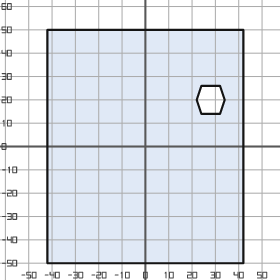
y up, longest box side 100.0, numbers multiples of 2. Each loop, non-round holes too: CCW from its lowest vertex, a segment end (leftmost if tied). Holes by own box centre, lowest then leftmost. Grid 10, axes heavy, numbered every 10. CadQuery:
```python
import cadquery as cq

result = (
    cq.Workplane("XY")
    .moveTo(-42.0, -50.0)
    .lineTo(42.0, -50.0)
    .lineTo(42.0, 50.0)
    .lineTo(-42.0, 50.0)
    .close()
    .moveTo(24.0, 14.0)
    .lineTo(32.0, 14.0)
    .lineTo(34.0, 20.0)
    .lineTo(32.0, 26.0)
    .lineTo(24.0, 26.0)
    .lineTo(22.0, 20.0)
    .close()
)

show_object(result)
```